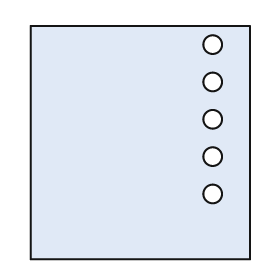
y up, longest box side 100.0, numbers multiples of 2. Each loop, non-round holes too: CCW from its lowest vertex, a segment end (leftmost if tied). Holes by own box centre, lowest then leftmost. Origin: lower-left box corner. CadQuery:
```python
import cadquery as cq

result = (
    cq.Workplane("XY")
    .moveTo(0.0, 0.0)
    .lineTo(94.0, 0.0)
    .lineTo(94.0, 100.0)
    .lineTo(0.0, 100.0)
    .close()
    .moveTo(78.0, 28.0)
    .circle(4.0)
    .moveTo(78.0, 44.0)
    .circle(4.0)
    .moveTo(78.0, 60.0)
    .circle(4.0)
    .moveTo(78.0, 76.0)
    .circle(4.0)
    .moveTo(78.0, 92.0)
    .circle(4.0)
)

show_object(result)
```